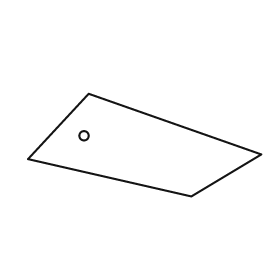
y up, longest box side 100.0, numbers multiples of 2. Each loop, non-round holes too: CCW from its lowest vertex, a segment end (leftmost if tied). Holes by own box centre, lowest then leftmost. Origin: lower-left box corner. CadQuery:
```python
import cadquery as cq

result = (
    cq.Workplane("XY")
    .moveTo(70.0, 0.0)
    .lineTo(100.0, 18.0)
    .lineTo(26.0, 44.0)
    .lineTo(0.0, 16.0)
    .close()
    .moveTo(24.0, 26.0)
    .circle(2.0)
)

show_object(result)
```